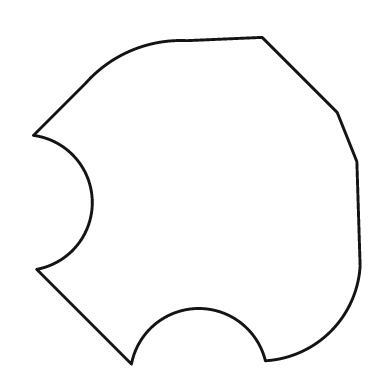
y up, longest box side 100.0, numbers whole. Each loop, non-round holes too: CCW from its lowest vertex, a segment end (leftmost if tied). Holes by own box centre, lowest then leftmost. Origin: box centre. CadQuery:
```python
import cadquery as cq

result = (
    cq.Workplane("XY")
    .moveTo(-20.0, -50.0)
    .threePointArc((0.0, -33.0), (21.0, -49.0))
    .threePointArc((41.0, -40.0), (50.0, -20.0))
    .lineTo(49.0, 12.0)
    .lineTo(43.0, 27.0)
    .lineTo(20.0, 50.0)
    .lineTo(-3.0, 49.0)
    .threePointArc((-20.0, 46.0), (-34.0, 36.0))
    .lineTo(-50.0, 20.0)
    .threePointArc((-32.0, 0.0), (-49.0, -21.0))
    .close()
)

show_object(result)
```